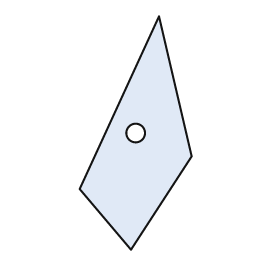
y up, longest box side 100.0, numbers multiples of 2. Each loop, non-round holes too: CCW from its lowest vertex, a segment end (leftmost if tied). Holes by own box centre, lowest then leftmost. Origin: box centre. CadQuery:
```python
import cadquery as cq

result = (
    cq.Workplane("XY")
    .moveTo(-2.0, -50.0)
    .lineTo(24.0, -10.0)
    .lineTo(10.0, 50.0)
    .lineTo(-24.0, -24.0)
    .close()
    .moveTo(0.0, 0.0)
    .circle(4.0)
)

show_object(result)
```